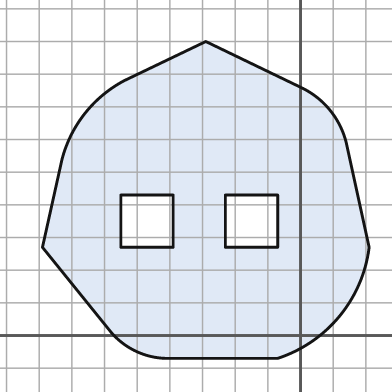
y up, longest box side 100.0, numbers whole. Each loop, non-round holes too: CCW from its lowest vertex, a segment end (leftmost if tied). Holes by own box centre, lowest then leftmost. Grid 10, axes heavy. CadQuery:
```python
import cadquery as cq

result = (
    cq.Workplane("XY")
    .moveTo(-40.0, -7.0)
    .lineTo(-7.0, -7.0)
    .threePointArc((12.0, 6.0), (21.0, 27.0))
    .lineTo(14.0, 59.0)
    .threePointArc((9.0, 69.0), (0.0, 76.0))
    .lineTo(-29.0, 90.0)
    .lineTo(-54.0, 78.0)
    .threePointArc((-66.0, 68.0), (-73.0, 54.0))
    .lineTo(-79.0, 27.0)
    .lineTo(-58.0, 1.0)
    .threePointArc((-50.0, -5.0), (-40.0, -7.0))
    .close()
    .moveTo(-55.0, 27.0)
    .lineTo(-39.0, 27.0)
    .lineTo(-39.0, 43.0)
    .lineTo(-55.0, 43.0)
    .close()
    .moveTo(-23.0, 27.0)
    .lineTo(-7.0, 27.0)
    .lineTo(-7.0, 43.0)
    .lineTo(-23.0, 43.0)
    .close()
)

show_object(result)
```